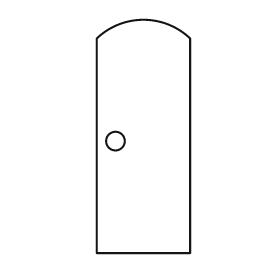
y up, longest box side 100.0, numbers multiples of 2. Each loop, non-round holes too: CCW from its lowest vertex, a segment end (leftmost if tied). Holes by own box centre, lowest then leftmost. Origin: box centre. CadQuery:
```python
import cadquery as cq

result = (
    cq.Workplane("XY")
    .moveTo(-20.0, -50.0)
    .lineTo(20.0, -50.0)
    .lineTo(20.0, 42.0)
    .threePointArc((0.0, 50.0), (-20.0, 42.0))
    .close()
    .moveTo(-12.0, -2.0)
    .circle(4.0)
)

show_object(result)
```